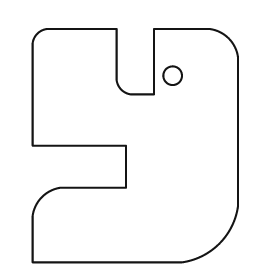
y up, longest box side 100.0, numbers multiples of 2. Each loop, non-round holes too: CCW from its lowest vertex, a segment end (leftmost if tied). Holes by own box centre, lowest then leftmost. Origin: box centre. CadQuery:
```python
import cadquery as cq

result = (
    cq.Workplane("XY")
    .moveTo(-44.0, -50.0)
    .lineTo(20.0, -50.0)
    .threePointArc((36.0, -42.0), (44.0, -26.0))
    .lineTo(44.0, 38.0)
    .threePointArc((40.0, 46.0), (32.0, 50.0))
    .lineTo(8.0, 50.0)
    .lineTo(8.0, 22.0)
    .lineTo(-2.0, 22.0)
    .threePointArc((-6.0, 24.0), (-8.0, 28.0))
    .lineTo(-8.0, 50.0)
    .lineTo(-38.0, 50.0)
    .threePointArc((-42.0, 48.0), (-44.0, 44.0))
    .lineTo(-44.0, 0.0)
    .lineTo(-4.0, 0.0)
    .lineTo(-4.0, -18.0)
    .lineTo(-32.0, -18.0)
    .threePointArc((-40.0, -22.0), (-44.0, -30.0))
    .close()
    .moveTo(16.0, 30.0)
    .circle(4.0)
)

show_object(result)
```